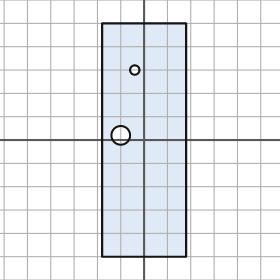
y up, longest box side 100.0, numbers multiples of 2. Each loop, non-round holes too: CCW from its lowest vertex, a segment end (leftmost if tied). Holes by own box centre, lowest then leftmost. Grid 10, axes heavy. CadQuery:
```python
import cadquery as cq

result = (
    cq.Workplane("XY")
    .moveTo(-18.0, -50.0)
    .lineTo(18.0, -50.0)
    .lineTo(18.0, 50.0)
    .lineTo(-18.0, 50.0)
    .close()
    .moveTo(-10.0, 2.0)
    .circle(4.0)
    .moveTo(-4.0, 30.0)
    .circle(2.0)
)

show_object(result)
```